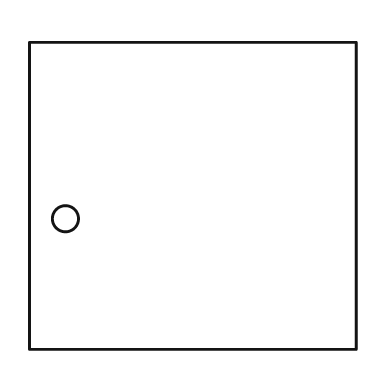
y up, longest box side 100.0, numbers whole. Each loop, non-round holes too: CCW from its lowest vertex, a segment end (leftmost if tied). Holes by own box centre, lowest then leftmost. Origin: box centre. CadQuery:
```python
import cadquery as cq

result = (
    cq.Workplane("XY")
    .moveTo(-50.0, -47.0)
    .lineTo(50.0, -47.0)
    .lineTo(50.0, 47.0)
    .lineTo(-50.0, 47.0)
    .close()
    .moveTo(-39.0, -7.0)
    .circle(4.0)
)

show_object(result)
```